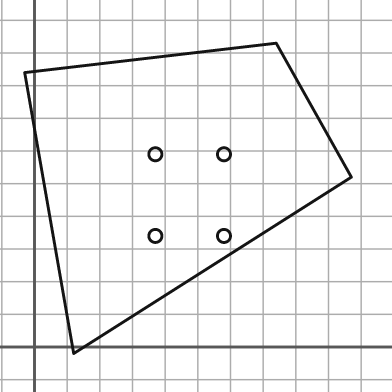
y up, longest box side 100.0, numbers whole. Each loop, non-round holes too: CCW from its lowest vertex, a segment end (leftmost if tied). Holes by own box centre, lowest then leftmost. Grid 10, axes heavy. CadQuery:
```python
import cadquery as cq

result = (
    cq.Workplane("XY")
    .moveTo(12.0, -2.0)
    .lineTo(97.0, 52.0)
    .lineTo(74.0, 93.0)
    .lineTo(-3.0, 84.0)
    .close()
    .moveTo(37.0, 34.0)
    .circle(2.0)
    .moveTo(58.0, 34.0)
    .circle(2.0)
    .moveTo(37.0, 59.0)
    .circle(2.0)
    .moveTo(58.0, 59.0)
    .circle(2.0)
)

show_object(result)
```